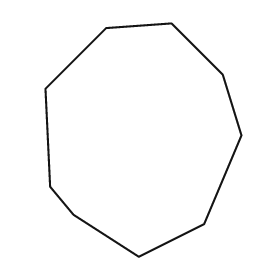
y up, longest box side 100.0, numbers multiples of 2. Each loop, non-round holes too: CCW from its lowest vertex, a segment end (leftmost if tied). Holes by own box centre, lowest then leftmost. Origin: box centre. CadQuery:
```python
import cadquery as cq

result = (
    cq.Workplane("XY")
    .moveTo(-2.0, -50.0)
    .lineTo(26.0, -36.0)
    .lineTo(42.0, 2.0)
    .lineTo(34.0, 28.0)
    .lineTo(12.0, 50.0)
    .lineTo(-16.0, 48.0)
    .lineTo(-42.0, 22.0)
    .lineTo(-40.0, -20.0)
    .lineTo(-30.0, -32.0)
    .close()
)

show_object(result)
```